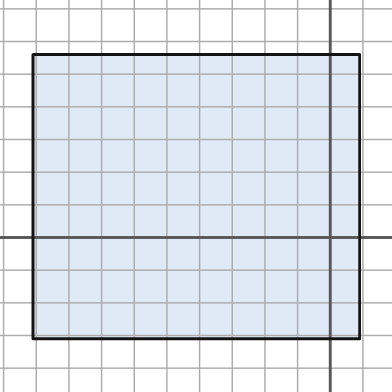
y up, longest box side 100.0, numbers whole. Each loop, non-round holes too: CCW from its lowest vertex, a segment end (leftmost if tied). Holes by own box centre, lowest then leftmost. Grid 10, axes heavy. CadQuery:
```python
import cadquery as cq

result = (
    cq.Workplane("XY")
    .moveTo(-91.0, -31.0)
    .lineTo(9.0, -31.0)
    .lineTo(9.0, 56.0)
    .lineTo(-91.0, 56.0)
    .close()
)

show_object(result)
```